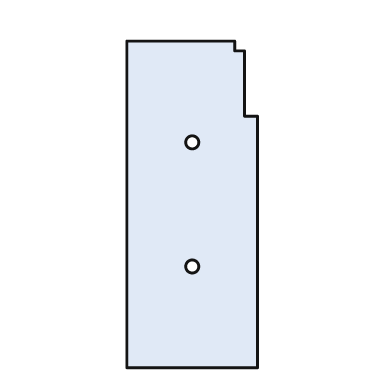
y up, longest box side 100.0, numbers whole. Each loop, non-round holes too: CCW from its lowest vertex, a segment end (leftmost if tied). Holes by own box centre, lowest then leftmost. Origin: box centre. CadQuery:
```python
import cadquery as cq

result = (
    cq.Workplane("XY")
    .moveTo(-20.0, -50.0)
    .lineTo(20.0, -50.0)
    .lineTo(20.0, 27.0)
    .lineTo(16.0, 27.0)
    .lineTo(16.0, 47.0)
    .lineTo(13.0, 47.0)
    .lineTo(13.0, 50.0)
    .lineTo(-20.0, 50.0)
    .close()
    .moveTo(0.0, -19.0)
    .circle(2.0)
    .moveTo(0.0, 19.0)
    .circle(2.0)
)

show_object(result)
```